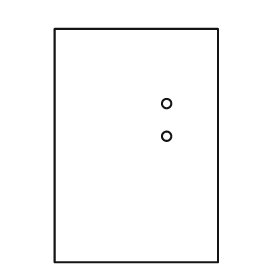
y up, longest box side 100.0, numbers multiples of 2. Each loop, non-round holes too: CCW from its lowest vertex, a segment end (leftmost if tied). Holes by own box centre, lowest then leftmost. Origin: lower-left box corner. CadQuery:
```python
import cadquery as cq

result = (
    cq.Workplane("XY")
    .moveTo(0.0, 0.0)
    .lineTo(70.0, 0.0)
    .lineTo(70.0, 100.0)
    .lineTo(0.0, 100.0)
    .close()
    .moveTo(48.0, 54.0)
    .circle(2.0)
    .moveTo(48.0, 68.0)
    .circle(2.0)
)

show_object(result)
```